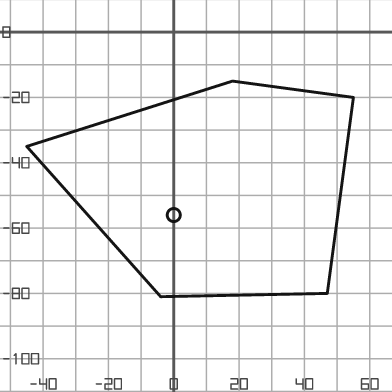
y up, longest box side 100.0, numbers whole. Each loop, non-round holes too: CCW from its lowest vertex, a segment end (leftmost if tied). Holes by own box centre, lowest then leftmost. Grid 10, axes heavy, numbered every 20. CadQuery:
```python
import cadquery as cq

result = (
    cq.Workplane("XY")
    .moveTo(-4.0, -81.0)
    .lineTo(47.0, -80.0)
    .lineTo(55.0, -20.0)
    .lineTo(18.0, -15.0)
    .lineTo(-45.0, -35.0)
    .close()
    .moveTo(0.0, -56.0)
    .circle(2.0)
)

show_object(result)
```